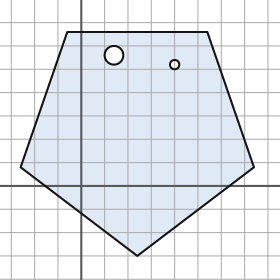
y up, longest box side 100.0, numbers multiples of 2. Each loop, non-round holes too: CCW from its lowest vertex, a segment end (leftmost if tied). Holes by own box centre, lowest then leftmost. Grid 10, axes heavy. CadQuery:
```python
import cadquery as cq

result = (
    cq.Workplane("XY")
    .moveTo(24.0, -30.0)
    .lineTo(74.0, 8.0)
    .lineTo(54.0, 66.0)
    .lineTo(-6.0, 66.0)
    .lineTo(-26.0, 8.0)
    .close()
    .moveTo(40.0, 52.0)
    .circle(2.0)
    .moveTo(14.0, 56.0)
    .circle(4.0)
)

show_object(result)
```